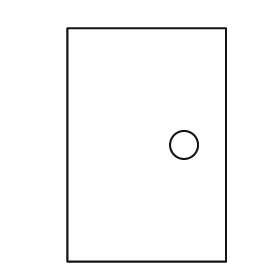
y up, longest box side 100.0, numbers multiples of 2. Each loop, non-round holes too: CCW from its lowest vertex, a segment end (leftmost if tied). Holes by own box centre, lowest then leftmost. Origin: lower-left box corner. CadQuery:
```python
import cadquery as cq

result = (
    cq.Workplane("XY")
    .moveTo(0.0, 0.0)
    .lineTo(68.0, 0.0)
    .lineTo(68.0, 100.0)
    .lineTo(0.0, 100.0)
    .close()
    .moveTo(50.0, 50.0)
    .circle(6.0)
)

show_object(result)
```